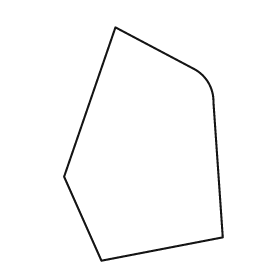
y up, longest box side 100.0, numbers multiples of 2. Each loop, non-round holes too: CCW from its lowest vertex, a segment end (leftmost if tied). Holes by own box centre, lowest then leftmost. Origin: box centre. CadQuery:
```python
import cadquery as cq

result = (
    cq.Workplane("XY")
    .moveTo(-18.0, -50.0)
    .lineTo(34.0, -40.0)
    .lineTo(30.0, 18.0)
    .threePointArc((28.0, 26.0), (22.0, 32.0))
    .lineTo(-12.0, 50.0)
    .lineTo(-34.0, -14.0)
    .close()
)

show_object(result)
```